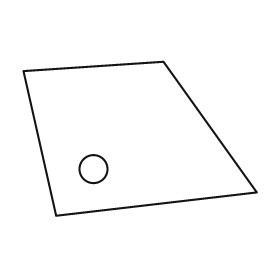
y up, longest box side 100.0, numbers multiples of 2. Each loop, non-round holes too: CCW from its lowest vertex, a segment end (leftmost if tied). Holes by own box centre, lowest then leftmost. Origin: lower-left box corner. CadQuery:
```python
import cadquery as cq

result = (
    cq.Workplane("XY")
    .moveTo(14.0, 0.0)
    .lineTo(100.0, 10.0)
    .lineTo(60.0, 66.0)
    .lineTo(0.0, 62.0)
    .close()
    .moveTo(30.0, 20.0)
    .circle(6.0)
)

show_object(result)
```